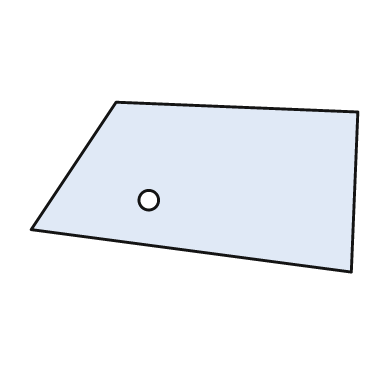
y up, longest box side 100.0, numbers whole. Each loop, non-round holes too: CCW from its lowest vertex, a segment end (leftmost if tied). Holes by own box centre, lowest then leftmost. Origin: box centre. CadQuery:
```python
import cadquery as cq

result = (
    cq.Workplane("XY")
    .moveTo(48.0, -26.0)
    .lineTo(50.0, 23.0)
    .lineTo(-24.0, 26.0)
    .lineTo(-50.0, -13.0)
    .close()
    .moveTo(-14.0, -4.0)
    .circle(3.0)
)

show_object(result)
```